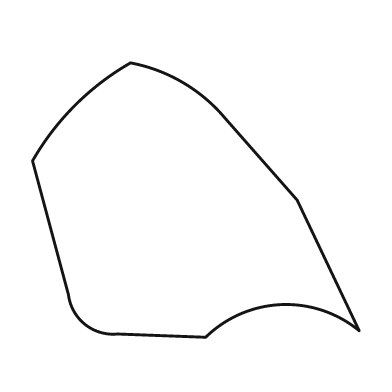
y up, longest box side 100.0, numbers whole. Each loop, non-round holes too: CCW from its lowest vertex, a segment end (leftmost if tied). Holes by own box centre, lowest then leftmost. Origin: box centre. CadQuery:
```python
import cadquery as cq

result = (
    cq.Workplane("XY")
    .moveTo(3.0, -42.0)
    .threePointArc((26.0, -32.0), (50.0, -40.0))
    .lineTo(31.0, 0.0)
    .lineTo(9.0, 25.0)
    .threePointArc((-4.0, 36.0), (-20.0, 42.0))
    .threePointArc((-37.0, 29.0), (-50.0, 12.0))
    .lineTo(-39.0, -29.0)
    .threePointArc((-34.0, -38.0), (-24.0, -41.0))
    .close()
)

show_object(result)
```